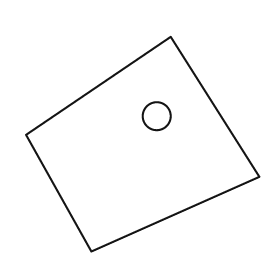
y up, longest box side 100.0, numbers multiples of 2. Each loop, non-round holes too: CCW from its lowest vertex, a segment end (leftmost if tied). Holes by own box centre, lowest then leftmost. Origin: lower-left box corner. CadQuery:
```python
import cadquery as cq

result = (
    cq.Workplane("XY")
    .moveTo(28.0, 0.0)
    .lineTo(100.0, 32.0)
    .lineTo(62.0, 92.0)
    .lineTo(0.0, 50.0)
    .close()
    .moveTo(56.0, 58.0)
    .circle(6.0)
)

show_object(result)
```